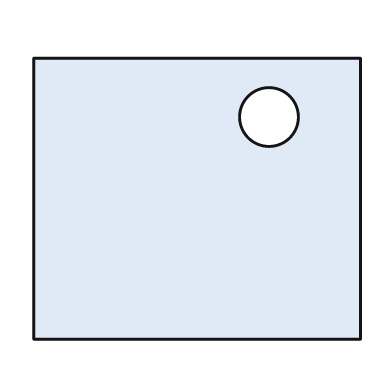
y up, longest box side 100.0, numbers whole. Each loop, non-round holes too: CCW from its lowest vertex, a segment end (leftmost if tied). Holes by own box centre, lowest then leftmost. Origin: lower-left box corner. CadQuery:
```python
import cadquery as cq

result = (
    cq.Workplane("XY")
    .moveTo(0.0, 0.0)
    .lineTo(100.0, 0.0)
    .lineTo(100.0, 86.0)
    .lineTo(0.0, 86.0)
    .close()
    .moveTo(72.0, 68.0)
    .circle(9.0)
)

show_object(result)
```